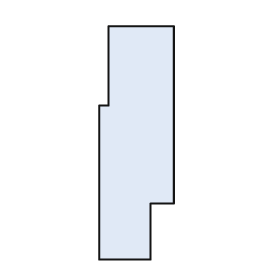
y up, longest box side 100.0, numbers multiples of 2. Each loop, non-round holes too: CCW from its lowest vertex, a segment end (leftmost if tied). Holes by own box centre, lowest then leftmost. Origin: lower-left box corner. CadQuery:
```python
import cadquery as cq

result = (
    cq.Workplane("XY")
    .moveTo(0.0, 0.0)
    .lineTo(22.0, 0.0)
    .lineTo(22.0, 24.0)
    .lineTo(32.0, 24.0)
    .lineTo(32.0, 100.0)
    .lineTo(4.0, 100.0)
    .lineTo(4.0, 66.0)
    .lineTo(0.0, 66.0)
    .close()
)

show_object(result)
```